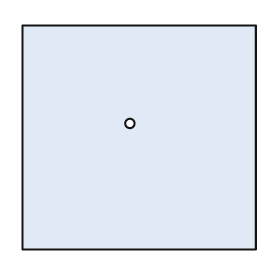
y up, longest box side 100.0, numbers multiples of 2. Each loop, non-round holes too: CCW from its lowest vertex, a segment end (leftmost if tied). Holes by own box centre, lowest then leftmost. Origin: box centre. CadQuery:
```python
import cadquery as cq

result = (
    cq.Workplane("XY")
    .moveTo(-50.0, -48.0)
    .lineTo(50.0, -48.0)
    .lineTo(50.0, 48.0)
    .lineTo(-50.0, 48.0)
    .close()
    .moveTo(-4.0, 6.0)
    .circle(2.0)
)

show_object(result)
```